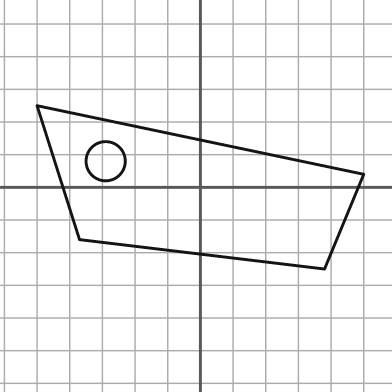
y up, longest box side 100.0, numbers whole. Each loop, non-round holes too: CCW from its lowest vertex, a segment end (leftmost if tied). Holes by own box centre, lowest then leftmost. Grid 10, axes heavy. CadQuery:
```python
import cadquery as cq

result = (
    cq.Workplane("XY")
    .moveTo(38.0, -25.0)
    .lineTo(50.0, 4.0)
    .lineTo(-50.0, 25.0)
    .lineTo(-37.0, -16.0)
    .close()
    .moveTo(-29.0, 8.0)
    .circle(6.0)
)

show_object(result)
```